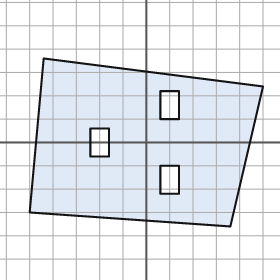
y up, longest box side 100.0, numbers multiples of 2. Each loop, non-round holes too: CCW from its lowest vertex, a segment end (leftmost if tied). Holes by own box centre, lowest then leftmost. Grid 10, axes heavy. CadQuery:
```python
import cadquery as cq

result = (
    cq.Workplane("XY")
    .moveTo(36.0, -36.0)
    .lineTo(50.0, 24.0)
    .lineTo(-44.0, 36.0)
    .lineTo(-50.0, -30.0)
    .close()
    .moveTo(6.0, -22.0)
    .lineTo(14.0, -22.0)
    .lineTo(14.0, -10.0)
    .lineTo(6.0, -10.0)
    .close()
    .moveTo(-24.0, -6.0)
    .lineTo(-16.0, -6.0)
    .lineTo(-16.0, 6.0)
    .lineTo(-24.0, 6.0)
    .close()
    .moveTo(6.0, 10.0)
    .lineTo(14.0, 10.0)
    .lineTo(14.0, 22.0)
    .lineTo(6.0, 22.0)
    .close()
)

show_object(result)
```